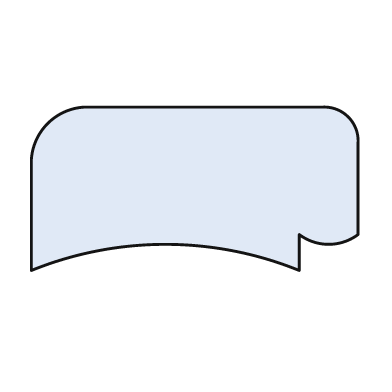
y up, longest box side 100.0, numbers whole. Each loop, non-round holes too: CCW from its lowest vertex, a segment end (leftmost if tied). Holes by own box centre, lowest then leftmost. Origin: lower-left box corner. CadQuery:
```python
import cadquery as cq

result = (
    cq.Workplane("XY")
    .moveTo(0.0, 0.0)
    .threePointArc((41.0, 8.0), (82.0, 0.0))
    .lineTo(82.0, 11.0)
    .threePointArc((91.0, 8.0), (100.0, 11.0))
    .lineTo(100.0, 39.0)
    .threePointArc((97.0, 47.0), (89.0, 50.0))
    .lineTo(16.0, 50.0)
    .threePointArc((5.0, 45.0), (0.0, 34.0))
    .close()
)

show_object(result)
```